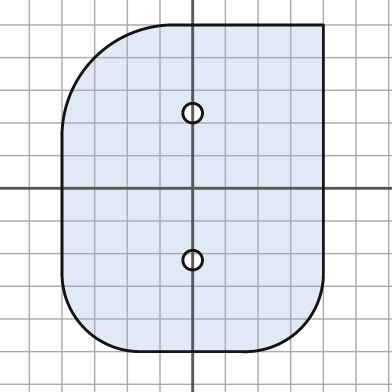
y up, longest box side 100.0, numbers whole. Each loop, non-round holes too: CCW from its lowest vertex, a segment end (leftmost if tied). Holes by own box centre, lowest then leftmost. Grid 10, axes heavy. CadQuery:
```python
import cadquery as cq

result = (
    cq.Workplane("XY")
    .moveTo(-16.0, -50.0)
    .lineTo(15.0, -50.0)
    .threePointArc((33.0, -43.0), (40.0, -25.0))
    .lineTo(40.0, 50.0)
    .lineTo(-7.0, 50.0)
    .threePointArc((-30.0, 40.0), (-40.0, 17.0))
    .lineTo(-40.0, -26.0)
    .threePointArc((-33.0, -43.0), (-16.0, -50.0))
    .close()
    .moveTo(0.0, -22.0)
    .circle(3.0)
    .moveTo(0.0, 23.0)
    .circle(3.0)
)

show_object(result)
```